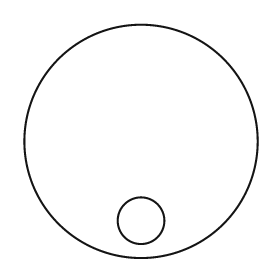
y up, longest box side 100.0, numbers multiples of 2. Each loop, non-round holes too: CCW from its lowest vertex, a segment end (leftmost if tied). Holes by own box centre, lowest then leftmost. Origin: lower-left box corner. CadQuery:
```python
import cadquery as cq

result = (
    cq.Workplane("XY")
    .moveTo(50.0, 50.0)
    .circle(50.0)
    .moveTo(50.0, 16.0)
    .circle(10.0)
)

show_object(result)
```